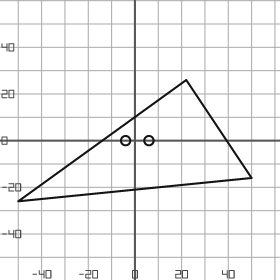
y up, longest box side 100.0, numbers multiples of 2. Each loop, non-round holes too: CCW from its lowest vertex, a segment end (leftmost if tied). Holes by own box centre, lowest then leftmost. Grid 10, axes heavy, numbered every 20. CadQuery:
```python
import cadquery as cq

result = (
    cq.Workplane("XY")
    .moveTo(-50.0, -26.0)
    .lineTo(50.0, -16.0)
    .lineTo(22.0, 26.0)
    .close()
    .moveTo(-4.0, 0.0)
    .circle(2.0)
    .moveTo(6.0, 0.0)
    .circle(2.0)
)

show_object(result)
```